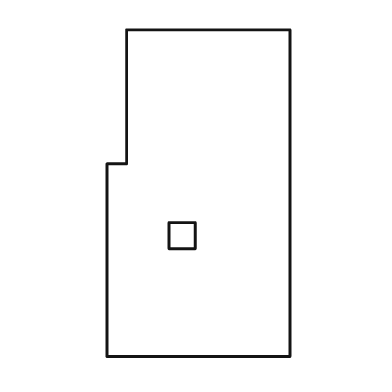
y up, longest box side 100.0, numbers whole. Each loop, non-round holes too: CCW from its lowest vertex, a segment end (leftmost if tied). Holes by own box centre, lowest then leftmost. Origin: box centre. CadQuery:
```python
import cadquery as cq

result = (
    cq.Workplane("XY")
    .moveTo(-28.0, -50.0)
    .lineTo(28.0, -50.0)
    .lineTo(28.0, 50.0)
    .lineTo(-22.0, 50.0)
    .lineTo(-22.0, 9.0)
    .lineTo(-28.0, 9.0)
    .close()
    .moveTo(-9.0, -17.0)
    .lineTo(-1.0, -17.0)
    .lineTo(-1.0, -9.0)
    .lineTo(-9.0, -9.0)
    .close()
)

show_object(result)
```